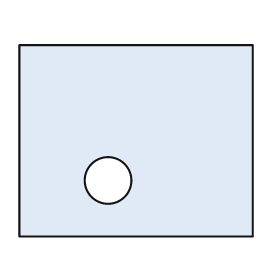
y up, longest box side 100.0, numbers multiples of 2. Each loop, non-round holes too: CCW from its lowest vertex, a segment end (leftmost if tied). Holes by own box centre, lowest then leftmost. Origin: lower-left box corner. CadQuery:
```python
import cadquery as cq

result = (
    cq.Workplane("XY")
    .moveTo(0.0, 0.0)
    .lineTo(100.0, 0.0)
    .lineTo(100.0, 82.0)
    .lineTo(0.0, 82.0)
    .close()
    .moveTo(38.0, 24.0)
    .circle(10.0)
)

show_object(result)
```